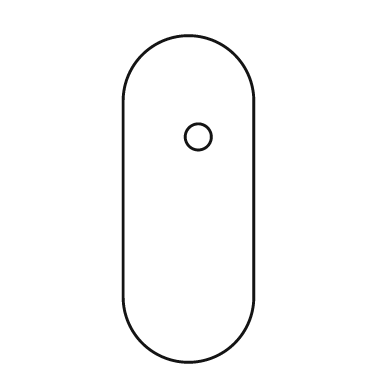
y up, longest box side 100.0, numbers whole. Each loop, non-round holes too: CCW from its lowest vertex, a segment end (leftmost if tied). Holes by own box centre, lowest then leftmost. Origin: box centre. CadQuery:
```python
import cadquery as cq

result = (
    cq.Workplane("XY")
    .moveTo(-20.0, -30.0)
    .threePointArc((0.0, -50.0), (20.0, -30.0))
    .lineTo(20.0, 30.0)
    .threePointArc((0.0, 50.0), (-20.0, 30.0))
    .close()
    .moveTo(3.0, 19.0)
    .circle(4.0)
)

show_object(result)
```